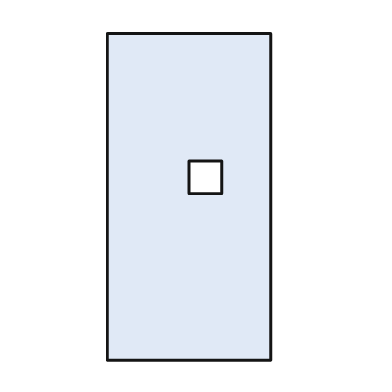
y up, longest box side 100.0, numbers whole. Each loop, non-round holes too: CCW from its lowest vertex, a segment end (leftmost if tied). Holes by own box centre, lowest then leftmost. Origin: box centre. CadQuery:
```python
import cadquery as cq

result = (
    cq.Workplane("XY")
    .moveTo(-25.0, -50.0)
    .lineTo(25.0, -50.0)
    .lineTo(25.0, 50.0)
    .lineTo(-25.0, 50.0)
    .close()
    .moveTo(0.0, 1.0)
    .lineTo(10.0, 1.0)
    .lineTo(10.0, 11.0)
    .lineTo(0.0, 11.0)
    .close()
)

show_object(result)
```